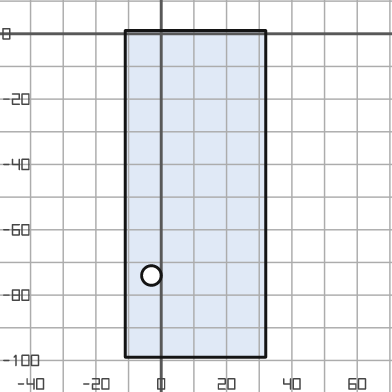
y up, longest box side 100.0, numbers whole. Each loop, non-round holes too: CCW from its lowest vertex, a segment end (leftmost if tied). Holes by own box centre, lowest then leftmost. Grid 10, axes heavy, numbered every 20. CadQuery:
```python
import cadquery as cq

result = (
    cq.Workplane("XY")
    .moveTo(-11.0, -99.0)
    .lineTo(32.0, -99.0)
    .lineTo(32.0, 1.0)
    .lineTo(-11.0, 1.0)
    .close()
    .moveTo(-3.0, -74.0)
    .circle(3.0)
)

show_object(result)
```